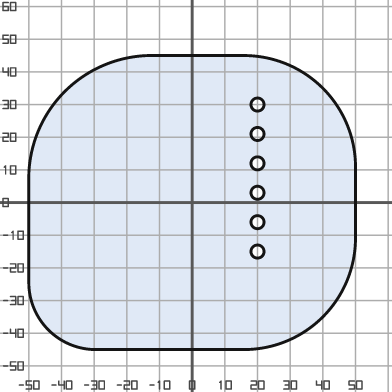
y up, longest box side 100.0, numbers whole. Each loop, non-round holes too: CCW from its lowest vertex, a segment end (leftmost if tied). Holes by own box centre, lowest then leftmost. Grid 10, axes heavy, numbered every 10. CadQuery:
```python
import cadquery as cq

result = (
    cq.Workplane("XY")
    .moveTo(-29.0, -45.0)
    .lineTo(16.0, -45.0)
    .threePointArc((40.0, -35.0), (50.0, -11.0))
    .lineTo(50.0, 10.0)
    .threePointArc((40.0, 35.0), (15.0, 45.0))
    .lineTo(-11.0, 45.0)
    .threePointArc((-39.0, 34.0), (-50.0, 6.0))
    .lineTo(-50.0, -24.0)
    .threePointArc((-44.0, -39.0), (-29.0, -45.0))
    .close()
    .moveTo(20.0, -15.0)
    .circle(2.0)
    .moveTo(20.0, -6.0)
    .circle(2.0)
    .moveTo(20.0, 3.0)
    .circle(2.0)
    .moveTo(20.0, 12.0)
    .circle(2.0)
    .moveTo(20.0, 21.0)
    .circle(2.0)
    .moveTo(20.0, 30.0)
    .circle(2.0)
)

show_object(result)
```